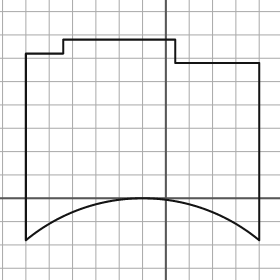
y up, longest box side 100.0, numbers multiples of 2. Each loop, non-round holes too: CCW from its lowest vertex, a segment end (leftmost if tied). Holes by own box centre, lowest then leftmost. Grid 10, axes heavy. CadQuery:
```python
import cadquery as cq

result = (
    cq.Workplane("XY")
    .moveTo(-60.0, -18.0)
    .threePointArc((-10.0, 0.0), (40.0, -18.0))
    .lineTo(40.0, 58.0)
    .lineTo(4.0, 58.0)
    .lineTo(4.0, 68.0)
    .lineTo(-44.0, 68.0)
    .lineTo(-44.0, 62.0)
    .lineTo(-60.0, 62.0)
    .close()
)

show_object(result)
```